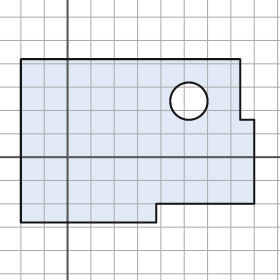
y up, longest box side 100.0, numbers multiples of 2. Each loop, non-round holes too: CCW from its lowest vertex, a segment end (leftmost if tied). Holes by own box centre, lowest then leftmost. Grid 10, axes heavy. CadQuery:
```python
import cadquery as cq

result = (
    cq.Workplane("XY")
    .moveTo(-20.0, -28.0)
    .lineTo(38.0, -28.0)
    .lineTo(38.0, -20.0)
    .lineTo(80.0, -20.0)
    .lineTo(80.0, 16.0)
    .lineTo(74.0, 16.0)
    .lineTo(74.0, 42.0)
    .lineTo(-20.0, 42.0)
    .close()
    .moveTo(52.0, 24.0)
    .circle(8.0)
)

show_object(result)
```